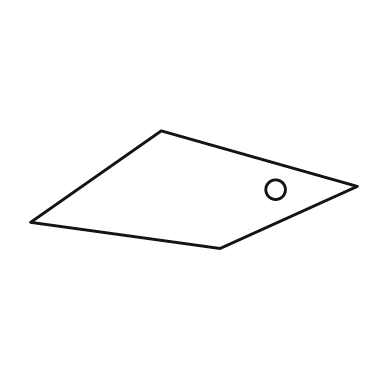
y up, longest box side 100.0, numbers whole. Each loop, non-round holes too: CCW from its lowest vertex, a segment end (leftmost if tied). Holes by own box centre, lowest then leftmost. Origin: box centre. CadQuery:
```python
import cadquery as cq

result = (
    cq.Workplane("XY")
    .moveTo(8.0, -18.0)
    .lineTo(50.0, 1.0)
    .lineTo(-10.0, 18.0)
    .lineTo(-50.0, -10.0)
    .close()
    .moveTo(25.0, 0.0)
    .circle(3.0)
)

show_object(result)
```